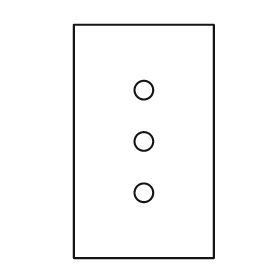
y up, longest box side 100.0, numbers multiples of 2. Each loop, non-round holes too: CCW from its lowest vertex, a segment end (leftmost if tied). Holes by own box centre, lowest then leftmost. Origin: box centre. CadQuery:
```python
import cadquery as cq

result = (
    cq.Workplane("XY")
    .moveTo(-30.0, -50.0)
    .lineTo(30.0, -50.0)
    .lineTo(30.0, 50.0)
    .lineTo(-30.0, 50.0)
    .close()
    .moveTo(0.0, -22.0)
    .circle(4.0)
    .moveTo(0.0, 0.0)
    .circle(4.0)
    .moveTo(0.0, 22.0)
    .circle(4.0)
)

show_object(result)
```